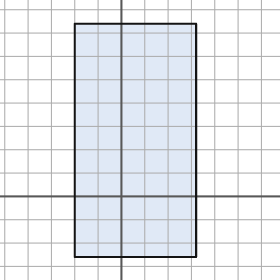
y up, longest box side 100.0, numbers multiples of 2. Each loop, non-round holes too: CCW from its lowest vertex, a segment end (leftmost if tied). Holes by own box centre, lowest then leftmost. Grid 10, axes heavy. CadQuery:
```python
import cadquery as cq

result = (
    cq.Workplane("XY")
    .moveTo(-20.0, -26.0)
    .lineTo(32.0, -26.0)
    .lineTo(32.0, 74.0)
    .lineTo(-20.0, 74.0)
    .close()
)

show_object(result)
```